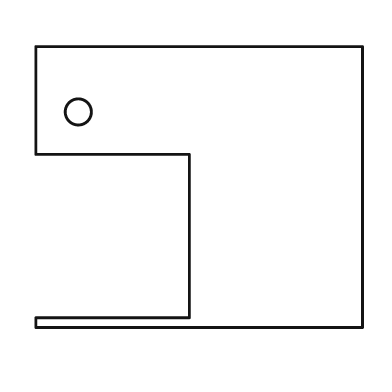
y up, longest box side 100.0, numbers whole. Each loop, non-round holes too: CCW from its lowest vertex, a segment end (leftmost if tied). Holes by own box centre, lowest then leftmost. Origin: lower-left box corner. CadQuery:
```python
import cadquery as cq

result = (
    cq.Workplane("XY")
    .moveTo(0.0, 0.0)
    .lineTo(100.0, 0.0)
    .lineTo(100.0, 86.0)
    .lineTo(0.0, 86.0)
    .lineTo(0.0, 53.0)
    .lineTo(47.0, 53.0)
    .lineTo(47.0, 3.0)
    .lineTo(0.0, 3.0)
    .close()
    .moveTo(13.0, 66.0)
    .circle(4.0)
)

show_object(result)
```